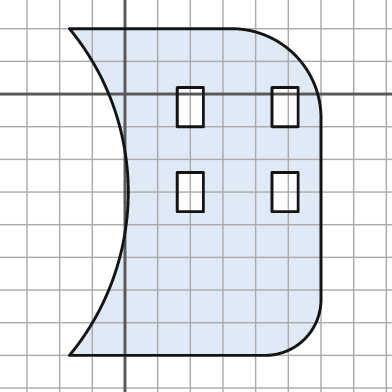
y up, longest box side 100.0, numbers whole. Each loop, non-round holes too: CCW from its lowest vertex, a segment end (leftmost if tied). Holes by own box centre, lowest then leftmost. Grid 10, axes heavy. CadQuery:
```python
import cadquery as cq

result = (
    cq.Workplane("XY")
    .moveTo(-17.0, -80.0)
    .lineTo(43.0, -80.0)
    .threePointArc((55.0, -75.0), (60.0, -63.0))
    .lineTo(60.0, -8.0)
    .threePointArc((52.0, 12.0), (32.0, 20.0))
    .lineTo(-17.0, 20.0)
    .threePointArc((1.0, -30.0), (-17.0, -80.0))
    .close()
    .moveTo(16.0, -36.0)
    .lineTo(24.0, -36.0)
    .lineTo(24.0, -24.0)
    .lineTo(16.0, -24.0)
    .close()
    .moveTo(45.0, -36.0)
    .lineTo(53.0, -36.0)
    .lineTo(53.0, -24.0)
    .lineTo(45.0, -24.0)
    .close()
    .moveTo(16.0, -10.0)
    .lineTo(24.0, -10.0)
    .lineTo(24.0, 2.0)
    .lineTo(16.0, 2.0)
    .close()
    .moveTo(45.0, -10.0)
    .lineTo(53.0, -10.0)
    .lineTo(53.0, 2.0)
    .lineTo(45.0, 2.0)
    .close()
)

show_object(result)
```